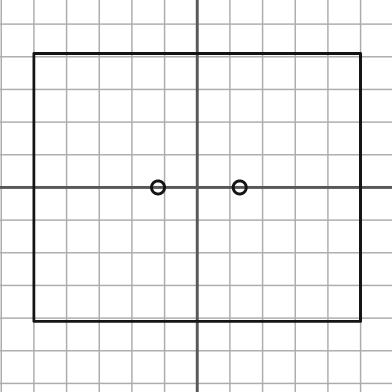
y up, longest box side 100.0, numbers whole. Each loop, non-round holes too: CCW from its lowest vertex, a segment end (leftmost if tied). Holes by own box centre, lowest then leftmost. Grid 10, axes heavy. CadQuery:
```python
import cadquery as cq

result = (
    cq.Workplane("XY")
    .moveTo(-50.0, -41.0)
    .lineTo(50.0, -41.0)
    .lineTo(50.0, 41.0)
    .lineTo(-50.0, 41.0)
    .close()
    .moveTo(-12.0, 0.0)
    .circle(2.0)
    .moveTo(13.0, 0.0)
    .circle(2.0)
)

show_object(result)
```